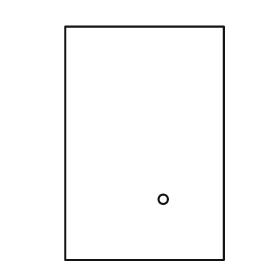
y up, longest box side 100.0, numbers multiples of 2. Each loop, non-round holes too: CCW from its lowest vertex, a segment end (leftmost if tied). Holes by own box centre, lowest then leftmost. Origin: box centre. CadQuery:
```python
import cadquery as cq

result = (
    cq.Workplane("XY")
    .moveTo(-34.0, -50.0)
    .lineTo(34.0, -50.0)
    .lineTo(34.0, 50.0)
    .lineTo(-34.0, 50.0)
    .close()
    .moveTo(8.0, -24.0)
    .circle(2.0)
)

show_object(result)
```